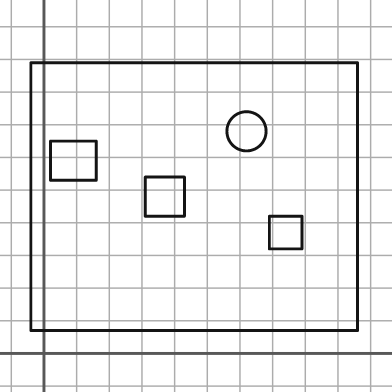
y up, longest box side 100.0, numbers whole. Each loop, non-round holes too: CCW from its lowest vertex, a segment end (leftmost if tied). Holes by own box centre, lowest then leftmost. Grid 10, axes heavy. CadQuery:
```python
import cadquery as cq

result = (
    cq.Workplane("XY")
    .moveTo(-4.0, 7.0)
    .lineTo(96.0, 7.0)
    .lineTo(96.0, 89.0)
    .lineTo(-4.0, 89.0)
    .close()
    .moveTo(69.0, 32.0)
    .lineTo(79.0, 32.0)
    .lineTo(79.0, 42.0)
    .lineTo(69.0, 42.0)
    .close()
    .moveTo(31.0, 42.0)
    .lineTo(43.0, 42.0)
    .lineTo(43.0, 54.0)
    .lineTo(31.0, 54.0)
    .close()
    .moveTo(2.0, 53.0)
    .lineTo(16.0, 53.0)
    .lineTo(16.0, 65.0)
    .lineTo(2.0, 65.0)
    .close()
    .moveTo(62.0, 68.0)
    .circle(6.0)
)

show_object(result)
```